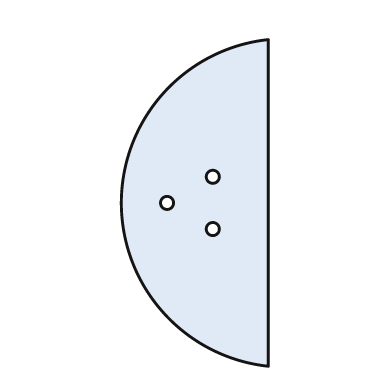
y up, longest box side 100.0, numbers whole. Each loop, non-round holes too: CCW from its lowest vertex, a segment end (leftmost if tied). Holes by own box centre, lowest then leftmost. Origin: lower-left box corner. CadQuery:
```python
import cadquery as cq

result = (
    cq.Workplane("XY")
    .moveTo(45.0, 0.0)
    .lineTo(45.0, 100.0)
    .threePointArc((0.0, 50.0), (45.0, 0.0))
    .close()
    .moveTo(28.0, 42.0)
    .circle(2.0)
    .moveTo(14.0, 50.0)
    .circle(2.0)
    .moveTo(28.0, 58.0)
    .circle(2.0)
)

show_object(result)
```